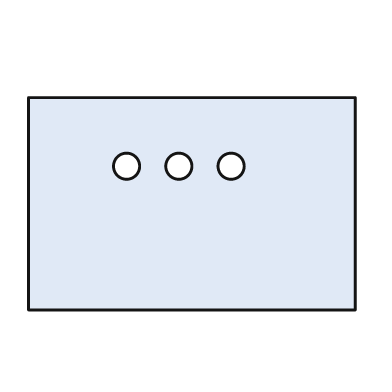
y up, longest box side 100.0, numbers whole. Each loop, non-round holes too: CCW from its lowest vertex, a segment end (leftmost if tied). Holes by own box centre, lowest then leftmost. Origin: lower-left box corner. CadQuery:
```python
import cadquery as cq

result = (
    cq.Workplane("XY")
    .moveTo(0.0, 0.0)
    .lineTo(100.0, 0.0)
    .lineTo(100.0, 65.0)
    .lineTo(0.0, 65.0)
    .close()
    .moveTo(30.0, 44.0)
    .circle(4.0)
    .moveTo(46.0, 44.0)
    .circle(4.0)
    .moveTo(62.0, 44.0)
    .circle(4.0)
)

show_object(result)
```